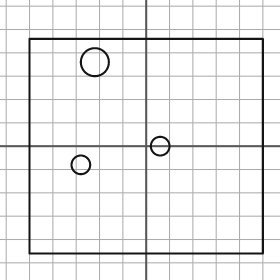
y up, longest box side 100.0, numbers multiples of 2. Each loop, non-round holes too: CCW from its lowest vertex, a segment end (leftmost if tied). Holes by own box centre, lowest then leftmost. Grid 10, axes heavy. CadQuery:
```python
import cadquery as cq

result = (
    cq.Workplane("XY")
    .moveTo(-50.0, -46.0)
    .lineTo(50.0, -46.0)
    .lineTo(50.0, 46.0)
    .lineTo(-50.0, 46.0)
    .close()
    .moveTo(-28.0, -8.0)
    .circle(4.0)
    .moveTo(6.0, 0.0)
    .circle(4.0)
    .moveTo(-22.0, 36.0)
    .circle(6.0)
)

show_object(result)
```